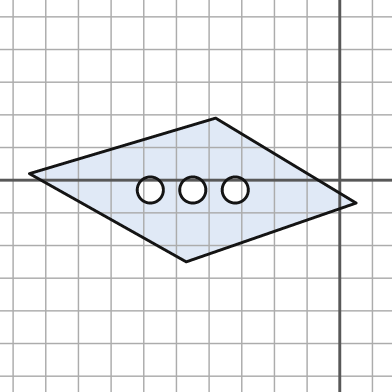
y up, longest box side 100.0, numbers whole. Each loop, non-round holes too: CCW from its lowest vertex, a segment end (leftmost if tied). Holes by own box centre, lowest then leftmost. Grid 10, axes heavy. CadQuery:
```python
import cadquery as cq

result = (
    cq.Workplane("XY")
    .moveTo(-47.0, -25.0)
    .lineTo(5.0, -7.0)
    .lineTo(-38.0, 19.0)
    .lineTo(-95.0, 2.0)
    .close()
    .moveTo(-58.0, -3.0)
    .circle(4.0)
    .moveTo(-45.0, -3.0)
    .circle(4.0)
    .moveTo(-32.0, -3.0)
    .circle(4.0)
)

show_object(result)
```